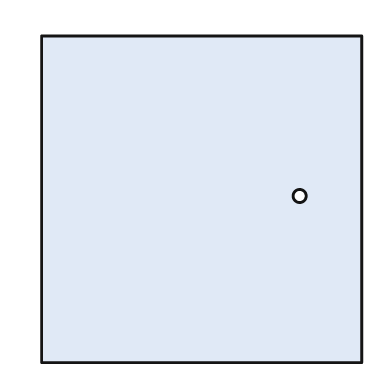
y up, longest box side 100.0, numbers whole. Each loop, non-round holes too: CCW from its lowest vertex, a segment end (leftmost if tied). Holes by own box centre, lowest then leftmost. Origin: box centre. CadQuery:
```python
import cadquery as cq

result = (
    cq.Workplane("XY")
    .moveTo(-49.0, -50.0)
    .lineTo(49.0, -50.0)
    .lineTo(49.0, 50.0)
    .lineTo(-49.0, 50.0)
    .close()
    .moveTo(30.0, 1.0)
    .circle(2.0)
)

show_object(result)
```